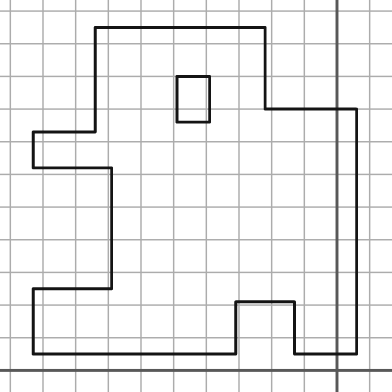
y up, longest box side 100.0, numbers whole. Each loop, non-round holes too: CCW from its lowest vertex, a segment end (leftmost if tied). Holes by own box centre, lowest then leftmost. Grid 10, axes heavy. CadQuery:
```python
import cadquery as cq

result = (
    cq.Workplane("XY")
    .moveTo(-93.0, 5.0)
    .lineTo(-31.0, 5.0)
    .lineTo(-31.0, 21.0)
    .lineTo(-13.0, 21.0)
    .lineTo(-13.0, 5.0)
    .lineTo(6.0, 5.0)
    .lineTo(6.0, 80.0)
    .lineTo(-22.0, 80.0)
    .lineTo(-22.0, 105.0)
    .lineTo(-74.0, 105.0)
    .lineTo(-74.0, 73.0)
    .lineTo(-93.0, 73.0)
    .lineTo(-93.0, 62.0)
    .lineTo(-69.0, 62.0)
    .lineTo(-69.0, 25.0)
    .lineTo(-93.0, 25.0)
    .close()
    .moveTo(-49.0, 76.0)
    .lineTo(-39.0, 76.0)
    .lineTo(-39.0, 90.0)
    .lineTo(-49.0, 90.0)
    .close()
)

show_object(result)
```